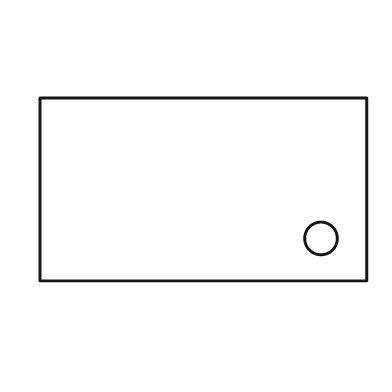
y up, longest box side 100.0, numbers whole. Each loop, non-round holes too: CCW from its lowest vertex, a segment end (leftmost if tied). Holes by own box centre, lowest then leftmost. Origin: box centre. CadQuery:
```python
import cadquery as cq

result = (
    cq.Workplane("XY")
    .moveTo(-50.0, -28.0)
    .lineTo(50.0, -28.0)
    .lineTo(50.0, 28.0)
    .lineTo(-50.0, 28.0)
    .close()
    .moveTo(36.0, -15.0)
    .circle(5.0)
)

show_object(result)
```